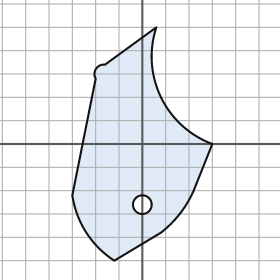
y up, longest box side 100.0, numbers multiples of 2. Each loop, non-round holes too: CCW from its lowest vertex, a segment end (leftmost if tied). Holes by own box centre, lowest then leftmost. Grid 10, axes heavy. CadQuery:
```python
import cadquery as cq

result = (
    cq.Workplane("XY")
    .moveTo(-12.0, -50.0)
    .lineTo(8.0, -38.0)
    .threePointArc((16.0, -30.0), (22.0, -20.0))
    .lineTo(30.0, 0.0)
    .threePointArc((8.0, 20.0), (6.0, 50.0))
    .lineTo(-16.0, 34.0)
    .threePointArc((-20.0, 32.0), (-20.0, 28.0))
    .lineTo(-30.0, -22.0)
    .threePointArc((-24.0, -38.0), (-12.0, -50.0))
    .close()
    .moveTo(0.0, -26.0)
    .circle(4.0)
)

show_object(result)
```